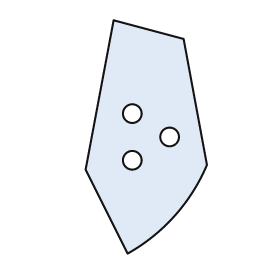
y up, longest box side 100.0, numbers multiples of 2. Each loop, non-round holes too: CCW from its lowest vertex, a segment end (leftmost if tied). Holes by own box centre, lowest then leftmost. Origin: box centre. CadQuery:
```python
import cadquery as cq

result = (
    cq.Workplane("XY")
    .moveTo(-8.0, -50.0)
    .threePointArc((12.0, -34.0), (26.0, -12.0))
    .lineTo(16.0, 42.0)
    .lineTo(-14.0, 50.0)
    .lineTo(-26.0, -14.0)
    .close()
    .moveTo(-6.0, -10.0)
    .circle(4.0)
    .moveTo(10.0, 0.0)
    .circle(4.0)
    .moveTo(-6.0, 10.0)
    .circle(4.0)
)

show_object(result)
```